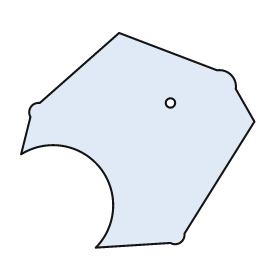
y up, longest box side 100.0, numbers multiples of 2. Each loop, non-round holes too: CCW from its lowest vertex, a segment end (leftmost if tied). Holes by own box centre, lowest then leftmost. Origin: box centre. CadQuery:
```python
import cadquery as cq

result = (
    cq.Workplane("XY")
    .moveTo(-18.0, -46.0)
    .lineTo(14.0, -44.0)
    .threePointArc((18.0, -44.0), (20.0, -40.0))
    .lineTo(50.0, 8.0)
    .lineTo(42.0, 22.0)
    .threePointArc((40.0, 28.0), (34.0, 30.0))
    .lineTo(-8.0, 46.0)
    .lineTo(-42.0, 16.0)
    .threePointArc((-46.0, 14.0), (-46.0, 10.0))
    .lineTo(-50.0, -6.0)
    .threePointArc((-16.0, -12.0), (-18.0, -46.0))
    .close()
    .moveTo(14.0, 16.0)
    .circle(2.0)
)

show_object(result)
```